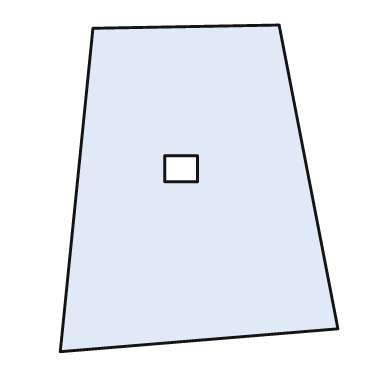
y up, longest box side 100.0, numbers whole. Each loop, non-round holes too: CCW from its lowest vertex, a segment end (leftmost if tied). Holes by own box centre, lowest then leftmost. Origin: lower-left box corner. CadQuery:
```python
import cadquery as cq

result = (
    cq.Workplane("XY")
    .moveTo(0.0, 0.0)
    .lineTo(85.0, 7.0)
    .lineTo(67.0, 100.0)
    .lineTo(10.0, 99.0)
    .close()
    .moveTo(32.0, 52.0)
    .lineTo(42.0, 52.0)
    .lineTo(42.0, 60.0)
    .lineTo(32.0, 60.0)
    .close()
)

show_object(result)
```